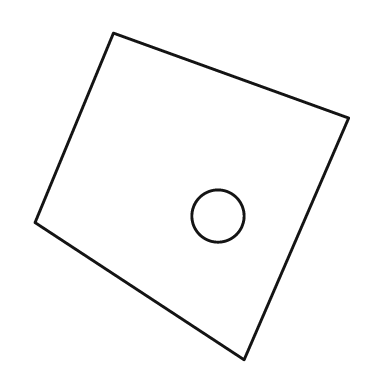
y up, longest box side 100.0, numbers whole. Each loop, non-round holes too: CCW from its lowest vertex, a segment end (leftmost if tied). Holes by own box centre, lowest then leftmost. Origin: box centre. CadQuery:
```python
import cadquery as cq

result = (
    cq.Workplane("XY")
    .moveTo(16.0, -50.0)
    .lineTo(48.0, 24.0)
    .lineTo(-24.0, 50.0)
    .lineTo(-48.0, -8.0)
    .close()
    .moveTo(8.0, -6.0)
    .circle(8.0)
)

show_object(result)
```